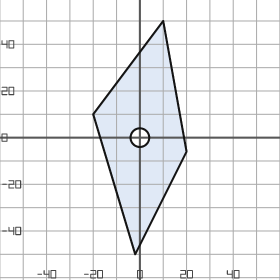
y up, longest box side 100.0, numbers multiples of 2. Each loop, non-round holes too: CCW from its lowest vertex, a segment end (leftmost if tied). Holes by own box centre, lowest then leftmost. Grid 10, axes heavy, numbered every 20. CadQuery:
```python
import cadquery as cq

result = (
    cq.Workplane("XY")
    .moveTo(-2.0, -50.0)
    .lineTo(20.0, -6.0)
    .lineTo(10.0, 50.0)
    .lineTo(-20.0, 10.0)
    .close()
    .moveTo(0.0, 0.0)
    .circle(4.0)
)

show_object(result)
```